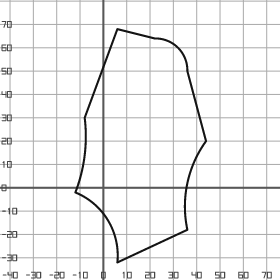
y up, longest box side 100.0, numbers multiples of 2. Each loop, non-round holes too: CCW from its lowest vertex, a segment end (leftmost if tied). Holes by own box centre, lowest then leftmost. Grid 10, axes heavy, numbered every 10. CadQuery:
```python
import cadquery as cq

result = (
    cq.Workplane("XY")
    .moveTo(6.0, -32.0)
    .lineTo(36.0, -18.0)
    .threePointArc((36.0, 2.0), (44.0, 20.0))
    .lineTo(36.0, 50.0)
    .threePointArc((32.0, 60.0), (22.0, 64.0))
    .lineTo(6.0, 68.0)
    .lineTo(-8.0, 30.0)
    .threePointArc((-8.0, 14.0), (-12.0, -2.0))
    .threePointArc((2.0, -14.0), (6.0, -32.0))
    .close()
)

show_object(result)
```